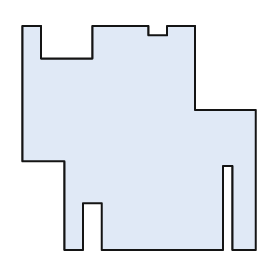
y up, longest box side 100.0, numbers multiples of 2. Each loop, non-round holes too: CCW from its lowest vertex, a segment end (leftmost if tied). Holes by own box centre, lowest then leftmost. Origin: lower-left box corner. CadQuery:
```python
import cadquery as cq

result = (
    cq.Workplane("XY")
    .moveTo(18.0, 0.0)
    .lineTo(26.0, 0.0)
    .lineTo(26.0, 20.0)
    .lineTo(34.0, 20.0)
    .lineTo(34.0, 0.0)
    .lineTo(86.0, 0.0)
    .lineTo(86.0, 36.0)
    .lineTo(90.0, 36.0)
    .lineTo(90.0, 0.0)
    .lineTo(100.0, 0.0)
    .lineTo(100.0, 60.0)
    .lineTo(74.0, 60.0)
    .lineTo(74.0, 96.0)
    .lineTo(62.0, 96.0)
    .lineTo(62.0, 92.0)
    .lineTo(54.0, 92.0)
    .lineTo(54.0, 96.0)
    .lineTo(30.0, 96.0)
    .lineTo(30.0, 82.0)
    .lineTo(8.0, 82.0)
    .lineTo(8.0, 96.0)
    .lineTo(0.0, 96.0)
    .lineTo(0.0, 38.0)
    .lineTo(18.0, 38.0)
    .close()
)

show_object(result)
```